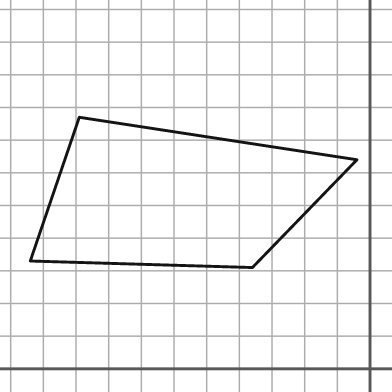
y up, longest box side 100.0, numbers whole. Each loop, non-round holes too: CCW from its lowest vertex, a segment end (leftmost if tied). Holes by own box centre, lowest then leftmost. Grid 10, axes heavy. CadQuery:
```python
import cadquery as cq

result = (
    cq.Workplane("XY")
    .moveTo(-36.0, 31.0)
    .lineTo(-4.0, 64.0)
    .lineTo(-89.0, 77.0)
    .lineTo(-104.0, 33.0)
    .close()
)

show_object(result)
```